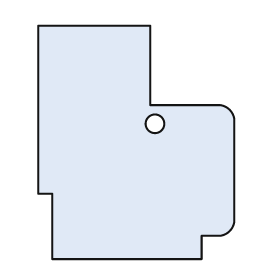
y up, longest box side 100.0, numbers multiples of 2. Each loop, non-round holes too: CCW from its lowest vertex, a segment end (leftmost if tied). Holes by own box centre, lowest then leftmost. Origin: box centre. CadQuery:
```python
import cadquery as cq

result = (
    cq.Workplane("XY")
    .moveTo(-36.0, -50.0)
    .lineTo(28.0, -50.0)
    .lineTo(28.0, -40.0)
    .lineTo(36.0, -40.0)
    .threePointArc((40.0, -38.0), (42.0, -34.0))
    .lineTo(42.0, 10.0)
    .threePointArc((40.0, 14.0), (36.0, 16.0))
    .lineTo(6.0, 16.0)
    .lineTo(6.0, 50.0)
    .lineTo(-42.0, 50.0)
    .lineTo(-42.0, -22.0)
    .lineTo(-36.0, -22.0)
    .close()
    .moveTo(8.0, 8.0)
    .circle(4.0)
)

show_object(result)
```